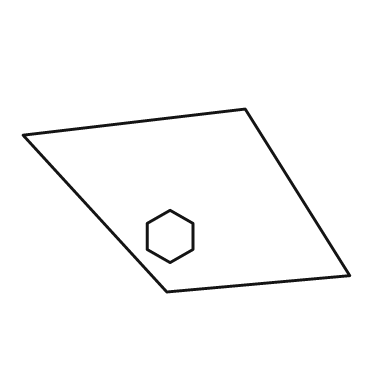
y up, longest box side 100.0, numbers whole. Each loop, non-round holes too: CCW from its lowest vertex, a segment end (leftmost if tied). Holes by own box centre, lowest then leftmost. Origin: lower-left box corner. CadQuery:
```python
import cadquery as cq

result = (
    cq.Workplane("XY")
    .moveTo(44.0, 0.0)
    .lineTo(100.0, 5.0)
    .lineTo(68.0, 56.0)
    .lineTo(0.0, 48.0)
    .close()
    .moveTo(45.0, 9.0)
    .lineTo(52.0, 13.0)
    .lineTo(52.0, 21.0)
    .lineTo(45.0, 25.0)
    .lineTo(38.0, 21.0)
    .lineTo(38.0, 13.0)
    .close()
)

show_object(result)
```